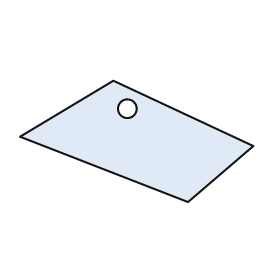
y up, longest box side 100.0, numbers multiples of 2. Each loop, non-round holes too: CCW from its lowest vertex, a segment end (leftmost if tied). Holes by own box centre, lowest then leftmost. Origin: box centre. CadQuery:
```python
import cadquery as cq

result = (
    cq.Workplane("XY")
    .moveTo(22.0, -26.0)
    .lineTo(50.0, -2.0)
    .lineTo(-10.0, 26.0)
    .lineTo(-50.0, 2.0)
    .close()
    .moveTo(-4.0, 14.0)
    .circle(4.0)
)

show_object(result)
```